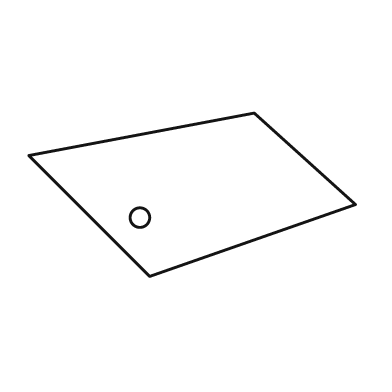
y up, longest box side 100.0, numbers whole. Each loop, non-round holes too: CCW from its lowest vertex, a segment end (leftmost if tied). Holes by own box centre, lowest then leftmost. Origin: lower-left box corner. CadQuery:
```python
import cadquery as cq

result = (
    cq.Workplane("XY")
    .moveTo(37.0, 0.0)
    .lineTo(100.0, 22.0)
    .lineTo(69.0, 50.0)
    .lineTo(0.0, 37.0)
    .close()
    .moveTo(34.0, 18.0)
    .circle(3.0)
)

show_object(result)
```